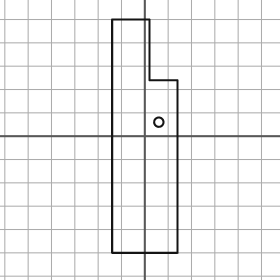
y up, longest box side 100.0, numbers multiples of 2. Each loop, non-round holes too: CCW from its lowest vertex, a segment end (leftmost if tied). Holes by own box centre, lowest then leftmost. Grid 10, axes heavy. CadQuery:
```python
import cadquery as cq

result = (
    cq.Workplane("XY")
    .moveTo(-14.0, -50.0)
    .lineTo(14.0, -50.0)
    .lineTo(14.0, 24.0)
    .lineTo(2.0, 24.0)
    .lineTo(2.0, 50.0)
    .lineTo(-14.0, 50.0)
    .close()
    .moveTo(6.0, 6.0)
    .circle(2.0)
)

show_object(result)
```